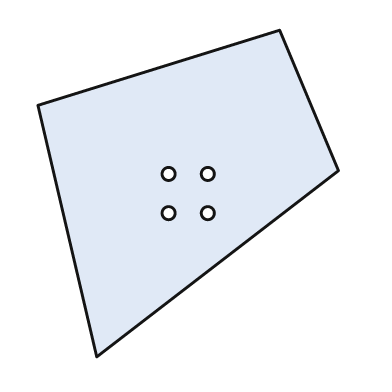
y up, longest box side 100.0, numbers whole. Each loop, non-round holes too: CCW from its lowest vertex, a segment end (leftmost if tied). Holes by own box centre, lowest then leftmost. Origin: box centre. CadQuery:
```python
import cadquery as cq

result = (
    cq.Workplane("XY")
    .moveTo(-28.0, -50.0)
    .lineTo(46.0, 7.0)
    .lineTo(28.0, 50.0)
    .lineTo(-46.0, 27.0)
    .close()
    .moveTo(-6.0, -6.0)
    .circle(2.0)
    .moveTo(6.0, -6.0)
    .circle(2.0)
    .moveTo(-6.0, 6.0)
    .circle(2.0)
    .moveTo(6.0, 6.0)
    .circle(2.0)
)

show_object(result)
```